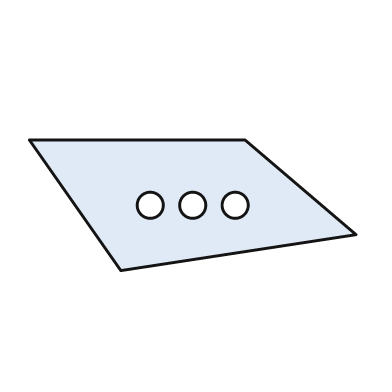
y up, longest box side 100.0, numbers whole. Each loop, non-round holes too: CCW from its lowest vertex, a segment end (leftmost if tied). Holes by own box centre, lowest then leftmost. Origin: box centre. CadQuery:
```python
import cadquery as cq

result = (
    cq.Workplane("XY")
    .moveTo(-22.0, -20.0)
    .lineTo(50.0, -9.0)
    .lineTo(16.0, 20.0)
    .lineTo(-50.0, 20.0)
    .close()
    .moveTo(-13.0, 0.0)
    .circle(4.0)
    .moveTo(0.0, 0.0)
    .circle(4.0)
    .moveTo(13.0, 0.0)
    .circle(4.0)
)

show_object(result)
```